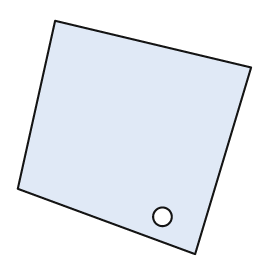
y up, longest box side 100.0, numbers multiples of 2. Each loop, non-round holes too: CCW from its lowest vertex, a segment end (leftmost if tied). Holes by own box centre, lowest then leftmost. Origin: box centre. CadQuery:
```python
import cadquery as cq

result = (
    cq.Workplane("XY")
    .moveTo(26.0, -50.0)
    .lineTo(50.0, 30.0)
    .lineTo(-34.0, 50.0)
    .lineTo(-50.0, -22.0)
    .close()
    .moveTo(12.0, -34.0)
    .circle(4.0)
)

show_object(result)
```